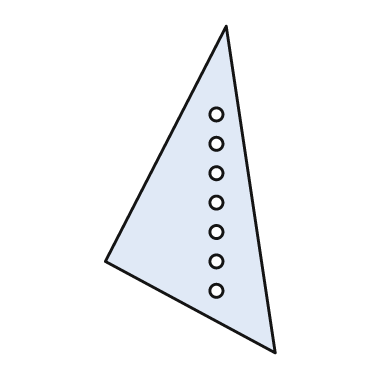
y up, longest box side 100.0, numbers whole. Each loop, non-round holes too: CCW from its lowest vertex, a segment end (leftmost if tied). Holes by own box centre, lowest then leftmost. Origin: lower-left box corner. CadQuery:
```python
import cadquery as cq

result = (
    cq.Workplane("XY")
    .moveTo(52.0, 0.0)
    .lineTo(37.0, 100.0)
    .lineTo(0.0, 28.0)
    .close()
    .moveTo(34.0, 19.0)
    .circle(2.0)
    .moveTo(34.0, 28.0)
    .circle(2.0)
    .moveTo(34.0, 37.0)
    .circle(2.0)
    .moveTo(34.0, 46.0)
    .circle(2.0)
    .moveTo(34.0, 55.0)
    .circle(2.0)
    .moveTo(34.0, 64.0)
    .circle(2.0)
    .moveTo(34.0, 73.0)
    .circle(2.0)
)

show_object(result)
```